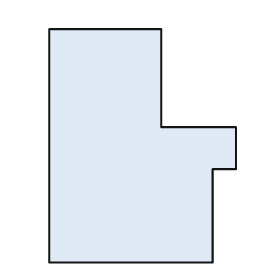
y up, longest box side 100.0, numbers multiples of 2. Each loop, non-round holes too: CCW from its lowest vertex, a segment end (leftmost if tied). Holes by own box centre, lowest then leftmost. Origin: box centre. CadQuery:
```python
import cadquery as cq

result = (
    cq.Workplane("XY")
    .moveTo(-40.0, -50.0)
    .lineTo(30.0, -50.0)
    .lineTo(30.0, -10.0)
    .lineTo(40.0, -10.0)
    .lineTo(40.0, 8.0)
    .lineTo(8.0, 8.0)
    .lineTo(8.0, 50.0)
    .lineTo(-40.0, 50.0)
    .close()
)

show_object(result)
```